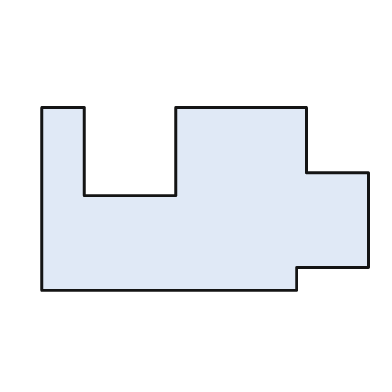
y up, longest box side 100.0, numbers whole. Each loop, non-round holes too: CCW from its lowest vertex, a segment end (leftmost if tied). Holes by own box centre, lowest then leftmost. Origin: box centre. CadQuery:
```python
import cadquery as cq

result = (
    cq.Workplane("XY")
    .moveTo(-50.0, -28.0)
    .lineTo(28.0, -28.0)
    .lineTo(28.0, -21.0)
    .lineTo(50.0, -21.0)
    .lineTo(50.0, 8.0)
    .lineTo(31.0, 8.0)
    .lineTo(31.0, 28.0)
    .lineTo(-9.0, 28.0)
    .lineTo(-9.0, 1.0)
    .lineTo(-37.0, 1.0)
    .lineTo(-37.0, 28.0)
    .lineTo(-50.0, 28.0)
    .close()
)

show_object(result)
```